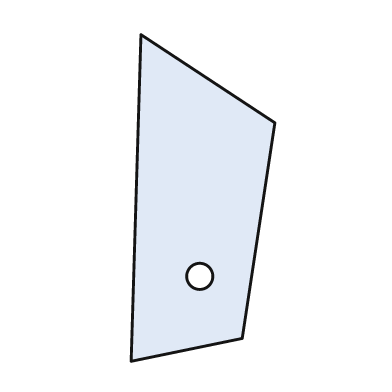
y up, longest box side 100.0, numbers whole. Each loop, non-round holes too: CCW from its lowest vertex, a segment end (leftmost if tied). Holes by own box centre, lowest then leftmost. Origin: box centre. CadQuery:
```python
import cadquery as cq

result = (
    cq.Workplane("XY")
    .moveTo(-22.0, -50.0)
    .lineTo(12.0, -43.0)
    .lineTo(22.0, 23.0)
    .lineTo(-19.0, 50.0)
    .close()
    .moveTo(-1.0, -24.0)
    .circle(4.0)
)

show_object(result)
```